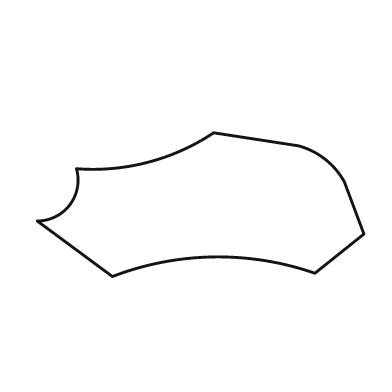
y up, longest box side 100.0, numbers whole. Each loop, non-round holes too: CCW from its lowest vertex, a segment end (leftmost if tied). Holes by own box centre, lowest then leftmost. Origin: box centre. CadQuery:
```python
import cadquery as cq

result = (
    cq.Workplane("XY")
    .moveTo(-27.0, -22.0)
    .threePointArc((4.0, -16.0), (35.0, -21.0))
    .lineTo(50.0, -9.0)
    .lineTo(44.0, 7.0)
    .threePointArc((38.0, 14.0), (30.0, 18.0))
    .lineTo(4.0, 22.0)
    .threePointArc((-16.0, 13.0), (-38.0, 11.0))
    .threePointArc((-40.0, 0.0), (-50.0, -5.0))
    .close()
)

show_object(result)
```